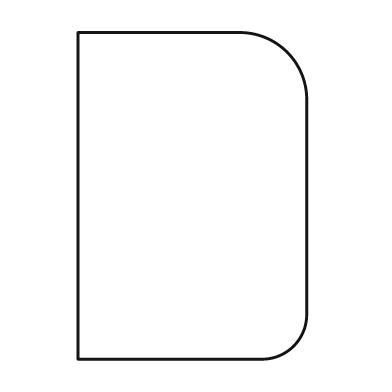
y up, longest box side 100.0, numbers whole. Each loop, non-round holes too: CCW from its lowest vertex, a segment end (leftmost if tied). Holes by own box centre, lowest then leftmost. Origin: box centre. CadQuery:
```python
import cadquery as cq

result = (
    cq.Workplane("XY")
    .moveTo(-35.0, -50.0)
    .lineTo(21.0, -50.0)
    .threePointArc((31.0, -46.0), (35.0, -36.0))
    .lineTo(35.0, 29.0)
    .threePointArc((29.0, 44.0), (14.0, 50.0))
    .lineTo(-35.0, 50.0)
    .close()
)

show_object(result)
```